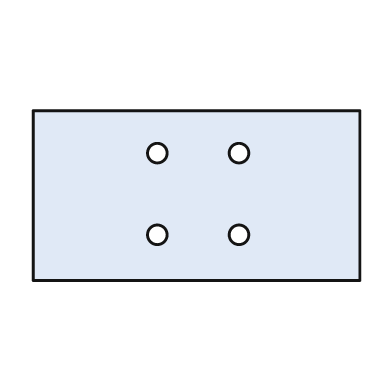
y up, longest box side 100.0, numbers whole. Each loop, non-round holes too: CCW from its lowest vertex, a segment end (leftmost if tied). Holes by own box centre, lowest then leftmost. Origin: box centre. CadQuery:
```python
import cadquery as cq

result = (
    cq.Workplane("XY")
    .moveTo(-50.0, -26.0)
    .lineTo(50.0, -26.0)
    .lineTo(50.0, 26.0)
    .lineTo(-50.0, 26.0)
    .close()
    .moveTo(-12.0, -12.0)
    .circle(3.0)
    .moveTo(13.0, -12.0)
    .circle(3.0)
    .moveTo(-12.0, 13.0)
    .circle(3.0)
    .moveTo(13.0, 13.0)
    .circle(3.0)
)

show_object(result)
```